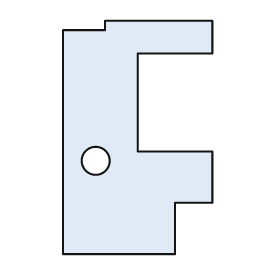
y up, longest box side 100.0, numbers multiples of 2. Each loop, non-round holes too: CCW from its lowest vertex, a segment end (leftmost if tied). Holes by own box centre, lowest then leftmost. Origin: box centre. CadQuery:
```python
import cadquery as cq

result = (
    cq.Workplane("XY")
    .moveTo(-32.0, -50.0)
    .lineTo(16.0, -50.0)
    .lineTo(16.0, -28.0)
    .lineTo(32.0, -28.0)
    .lineTo(32.0, -6.0)
    .lineTo(0.0, -6.0)
    .lineTo(0.0, 36.0)
    .lineTo(32.0, 36.0)
    .lineTo(32.0, 50.0)
    .lineTo(-14.0, 50.0)
    .lineTo(-14.0, 46.0)
    .lineTo(-32.0, 46.0)
    .close()
    .moveTo(-18.0, -10.0)
    .circle(6.0)
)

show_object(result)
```